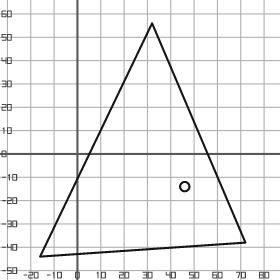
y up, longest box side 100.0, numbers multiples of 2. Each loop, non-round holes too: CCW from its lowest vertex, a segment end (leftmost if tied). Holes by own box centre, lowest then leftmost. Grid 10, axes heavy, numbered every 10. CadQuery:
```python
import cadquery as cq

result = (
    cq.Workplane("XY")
    .moveTo(-16.0, -44.0)
    .lineTo(72.0, -38.0)
    .lineTo(32.0, 56.0)
    .close()
    .moveTo(46.0, -14.0)
    .circle(2.0)
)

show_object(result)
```